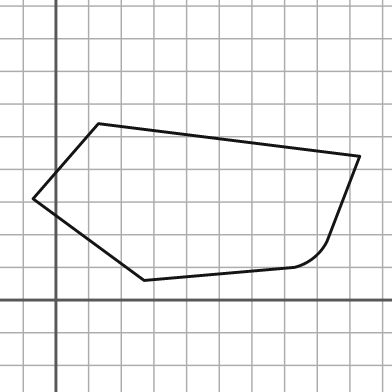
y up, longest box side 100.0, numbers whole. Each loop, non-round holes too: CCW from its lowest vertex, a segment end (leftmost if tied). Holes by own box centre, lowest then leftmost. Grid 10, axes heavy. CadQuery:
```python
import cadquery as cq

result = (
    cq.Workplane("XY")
    .moveTo(27.0, 6.0)
    .lineTo(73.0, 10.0)
    .threePointArc((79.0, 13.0), (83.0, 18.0))
    .lineTo(93.0, 44.0)
    .lineTo(13.0, 54.0)
    .lineTo(-7.0, 31.0)
    .close()
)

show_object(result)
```